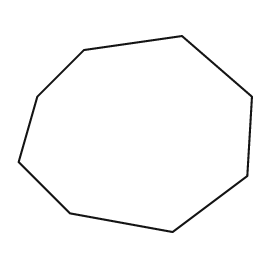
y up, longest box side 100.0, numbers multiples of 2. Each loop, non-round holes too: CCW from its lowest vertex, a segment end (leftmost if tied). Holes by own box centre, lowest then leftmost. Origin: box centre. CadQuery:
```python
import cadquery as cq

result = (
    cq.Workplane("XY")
    .moveTo(16.0, -42.0)
    .lineTo(48.0, -18.0)
    .lineTo(50.0, 16.0)
    .lineTo(20.0, 42.0)
    .lineTo(-22.0, 36.0)
    .lineTo(-42.0, 16.0)
    .lineTo(-50.0, -12.0)
    .lineTo(-28.0, -34.0)
    .close()
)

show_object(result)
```